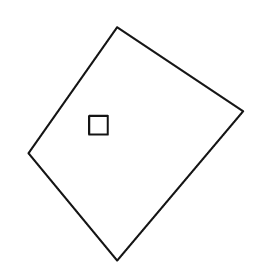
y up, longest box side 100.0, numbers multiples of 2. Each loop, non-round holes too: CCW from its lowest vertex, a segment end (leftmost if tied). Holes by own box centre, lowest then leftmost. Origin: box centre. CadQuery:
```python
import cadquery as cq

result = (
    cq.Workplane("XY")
    .moveTo(-8.0, -50.0)
    .lineTo(46.0, 14.0)
    .lineTo(-8.0, 50.0)
    .lineTo(-46.0, -4.0)
    .close()
    .moveTo(-20.0, 4.0)
    .lineTo(-12.0, 4.0)
    .lineTo(-12.0, 12.0)
    .lineTo(-20.0, 12.0)
    .close()
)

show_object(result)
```